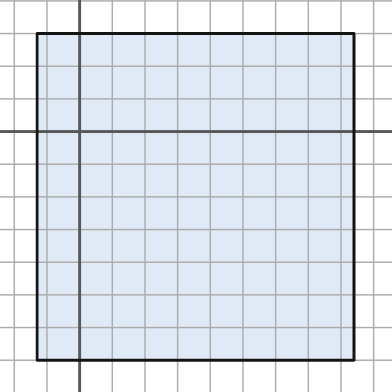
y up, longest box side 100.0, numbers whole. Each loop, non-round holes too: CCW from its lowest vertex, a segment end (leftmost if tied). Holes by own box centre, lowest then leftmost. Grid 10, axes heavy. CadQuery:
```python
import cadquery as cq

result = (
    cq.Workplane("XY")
    .moveTo(-13.0, -70.0)
    .lineTo(84.0, -70.0)
    .lineTo(84.0, 30.0)
    .lineTo(-13.0, 30.0)
    .close()
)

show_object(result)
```